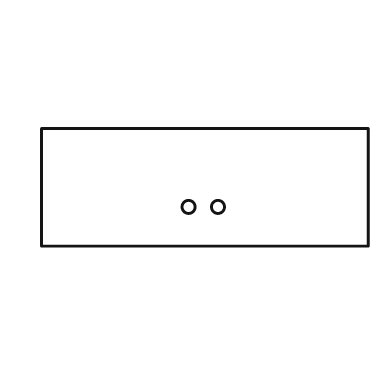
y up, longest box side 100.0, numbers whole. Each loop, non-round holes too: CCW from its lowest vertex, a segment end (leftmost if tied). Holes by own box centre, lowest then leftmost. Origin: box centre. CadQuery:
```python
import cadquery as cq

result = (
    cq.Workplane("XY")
    .moveTo(-50.0, -18.0)
    .lineTo(50.0, -18.0)
    .lineTo(50.0, 18.0)
    .lineTo(-50.0, 18.0)
    .close()
    .moveTo(-5.0, -6.0)
    .circle(2.0)
    .moveTo(4.0, -6.0)
    .circle(2.0)
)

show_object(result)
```